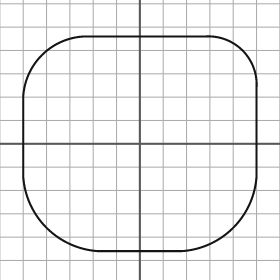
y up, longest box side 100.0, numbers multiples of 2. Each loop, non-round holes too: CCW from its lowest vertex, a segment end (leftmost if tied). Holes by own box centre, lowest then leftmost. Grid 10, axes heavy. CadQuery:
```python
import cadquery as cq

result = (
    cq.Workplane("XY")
    .moveTo(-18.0, -46.0)
    .lineTo(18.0, -46.0)
    .threePointArc((40.0, -36.0), (50.0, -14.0))
    .lineTo(50.0, 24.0)
    .threePointArc((44.0, 40.0), (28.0, 46.0))
    .lineTo(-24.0, 46.0)
    .threePointArc((-42.0, 38.0), (-50.0, 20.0))
    .lineTo(-50.0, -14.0)
    .threePointArc((-40.0, -36.0), (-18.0, -46.0))
    .close()
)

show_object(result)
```